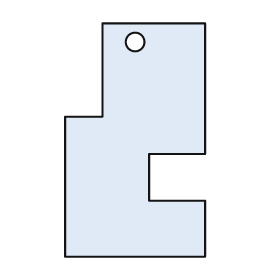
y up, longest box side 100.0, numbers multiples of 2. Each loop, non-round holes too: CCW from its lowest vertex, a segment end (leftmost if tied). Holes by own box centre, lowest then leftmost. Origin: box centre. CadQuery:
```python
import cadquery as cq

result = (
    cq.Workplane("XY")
    .moveTo(-30.0, -50.0)
    .lineTo(30.0, -50.0)
    .lineTo(30.0, -26.0)
    .lineTo(6.0, -26.0)
    .lineTo(6.0, -6.0)
    .lineTo(30.0, -6.0)
    .lineTo(30.0, 50.0)
    .lineTo(-14.0, 50.0)
    .lineTo(-14.0, 10.0)
    .lineTo(-30.0, 10.0)
    .close()
    .moveTo(0.0, 42.0)
    .circle(4.0)
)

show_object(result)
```